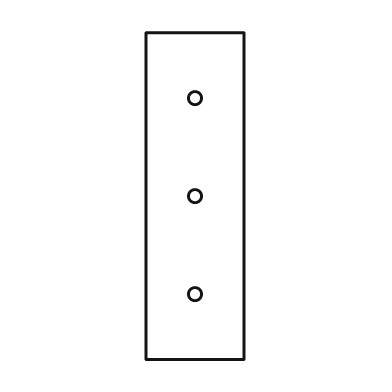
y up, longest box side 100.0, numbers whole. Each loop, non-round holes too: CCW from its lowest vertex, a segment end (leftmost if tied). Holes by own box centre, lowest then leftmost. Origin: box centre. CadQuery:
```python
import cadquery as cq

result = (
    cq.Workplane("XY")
    .moveTo(-15.0, -50.0)
    .lineTo(15.0, -50.0)
    .lineTo(15.0, 50.0)
    .lineTo(-15.0, 50.0)
    .close()
    .moveTo(0.0, -30.0)
    .circle(2.0)
    .moveTo(0.0, 0.0)
    .circle(2.0)
    .moveTo(0.0, 30.0)
    .circle(2.0)
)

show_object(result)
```